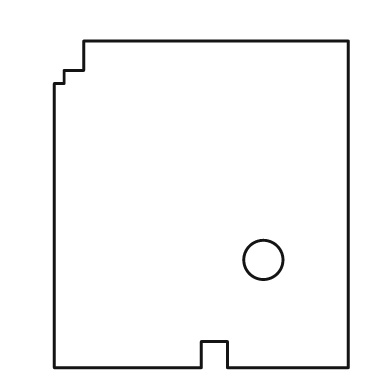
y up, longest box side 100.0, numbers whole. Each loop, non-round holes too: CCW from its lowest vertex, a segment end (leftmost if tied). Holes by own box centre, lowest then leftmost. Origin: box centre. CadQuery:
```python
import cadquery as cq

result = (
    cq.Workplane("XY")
    .moveTo(-45.0, -50.0)
    .lineTo(0.0, -50.0)
    .lineTo(0.0, -42.0)
    .lineTo(8.0, -42.0)
    .lineTo(8.0, -50.0)
    .lineTo(45.0, -50.0)
    .lineTo(45.0, 50.0)
    .lineTo(-36.0, 50.0)
    .lineTo(-36.0, 41.0)
    .lineTo(-42.0, 41.0)
    .lineTo(-42.0, 37.0)
    .lineTo(-45.0, 37.0)
    .close()
    .moveTo(19.0, -17.0)
    .circle(6.0)
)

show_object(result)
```